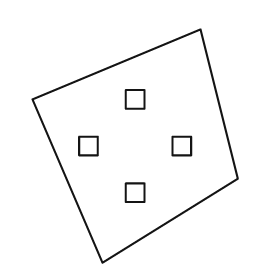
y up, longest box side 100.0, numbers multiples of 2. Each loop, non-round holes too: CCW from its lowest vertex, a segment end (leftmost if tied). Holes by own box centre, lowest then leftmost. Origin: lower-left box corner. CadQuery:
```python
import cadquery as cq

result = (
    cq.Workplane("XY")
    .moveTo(30.0, 0.0)
    .lineTo(88.0, 36.0)
    .lineTo(72.0, 100.0)
    .lineTo(0.0, 70.0)
    .close()
    .moveTo(40.0, 26.0)
    .lineTo(48.0, 26.0)
    .lineTo(48.0, 34.0)
    .lineTo(40.0, 34.0)
    .close()
    .moveTo(20.0, 46.0)
    .lineTo(28.0, 46.0)
    .lineTo(28.0, 54.0)
    .lineTo(20.0, 54.0)
    .close()
    .moveTo(60.0, 46.0)
    .lineTo(68.0, 46.0)
    .lineTo(68.0, 54.0)
    .lineTo(60.0, 54.0)
    .close()
    .moveTo(40.0, 66.0)
    .lineTo(48.0, 66.0)
    .lineTo(48.0, 74.0)
    .lineTo(40.0, 74.0)
    .close()
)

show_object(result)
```